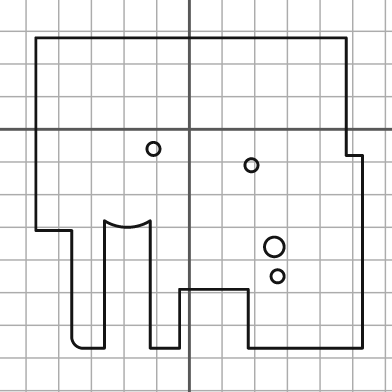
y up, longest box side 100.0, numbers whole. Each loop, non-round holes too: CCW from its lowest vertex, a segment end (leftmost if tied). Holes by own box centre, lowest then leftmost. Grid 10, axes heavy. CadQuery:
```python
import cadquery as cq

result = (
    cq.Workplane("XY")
    .moveTo(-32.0, -67.0)
    .lineTo(-26.0, -67.0)
    .lineTo(-26.0, -28.0)
    .threePointArc((-19.0, -30.0), (-12.0, -28.0))
    .lineTo(-12.0, -67.0)
    .lineTo(-3.0, -67.0)
    .lineTo(-3.0, -49.0)
    .lineTo(18.0, -49.0)
    .lineTo(18.0, -67.0)
    .lineTo(53.0, -67.0)
    .lineTo(53.0, -8.0)
    .lineTo(48.0, -8.0)
    .lineTo(48.0, 28.0)
    .lineTo(-47.0, 28.0)
    .lineTo(-47.0, -31.0)
    .lineTo(-36.0, -31.0)
    .lineTo(-36.0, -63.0)
    .threePointArc((-35.0, -66.0), (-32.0, -67.0))
    .close()
    .moveTo(27.0, -45.0)
    .circle(2.0)
    .moveTo(26.0, -36.0)
    .circle(3.0)
    .moveTo(19.0, -11.0)
    .circle(2.0)
    .moveTo(-11.0, -6.0)
    .circle(2.0)
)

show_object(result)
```